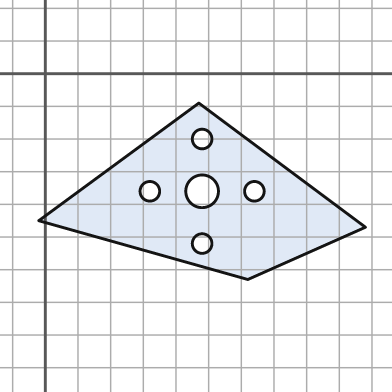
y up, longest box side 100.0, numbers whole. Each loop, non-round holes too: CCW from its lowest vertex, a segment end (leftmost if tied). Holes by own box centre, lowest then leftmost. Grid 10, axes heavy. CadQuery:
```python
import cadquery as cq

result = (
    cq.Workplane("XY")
    .moveTo(62.0, -63.0)
    .lineTo(98.0, -47.0)
    .lineTo(47.0, -9.0)
    .lineTo(-2.0, -45.0)
    .close()
    .moveTo(48.0, -52.0)
    .circle(3.0)
    .moveTo(32.0, -36.0)
    .circle(3.0)
    .moveTo(48.0, -36.0)
    .circle(5.0)
    .moveTo(64.0, -36.0)
    .circle(3.0)
    .moveTo(48.0, -20.0)
    .circle(3.0)
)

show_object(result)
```